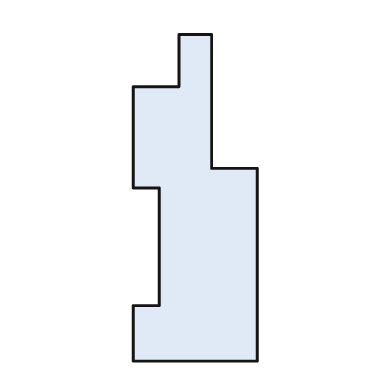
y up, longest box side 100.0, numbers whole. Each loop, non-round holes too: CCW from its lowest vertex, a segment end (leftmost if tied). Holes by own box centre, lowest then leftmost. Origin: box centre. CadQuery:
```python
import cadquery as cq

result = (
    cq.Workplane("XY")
    .moveTo(-19.0, -50.0)
    .lineTo(19.0, -50.0)
    .lineTo(19.0, 9.0)
    .lineTo(5.0, 9.0)
    .lineTo(5.0, 50.0)
    .lineTo(-5.0, 50.0)
    .lineTo(-5.0, 34.0)
    .lineTo(-19.0, 34.0)
    .lineTo(-19.0, 3.0)
    .lineTo(-11.0, 3.0)
    .lineTo(-11.0, -33.0)
    .lineTo(-19.0, -33.0)
    .close()
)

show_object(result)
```